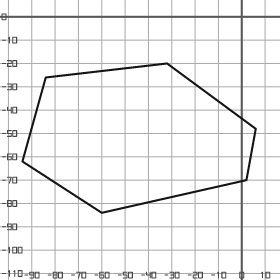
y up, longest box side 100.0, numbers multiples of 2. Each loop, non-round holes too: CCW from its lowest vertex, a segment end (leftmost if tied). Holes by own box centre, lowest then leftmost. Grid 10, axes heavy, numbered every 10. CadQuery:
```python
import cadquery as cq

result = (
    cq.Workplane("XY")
    .moveTo(-60.0, -84.0)
    .lineTo(2.0, -70.0)
    .lineTo(6.0, -48.0)
    .lineTo(-32.0, -20.0)
    .lineTo(-84.0, -26.0)
    .lineTo(-94.0, -62.0)
    .close()
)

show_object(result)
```